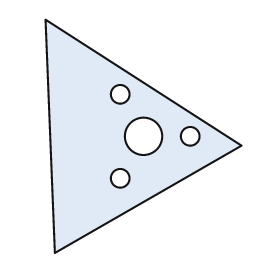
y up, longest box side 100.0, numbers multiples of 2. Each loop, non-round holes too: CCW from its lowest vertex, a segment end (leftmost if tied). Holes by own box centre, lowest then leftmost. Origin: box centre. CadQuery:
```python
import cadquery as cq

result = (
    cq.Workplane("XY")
    .moveTo(-38.0, -50.0)
    .lineTo(42.0, -4.0)
    .lineTo(-42.0, 50.0)
    .close()
    .moveTo(-10.0, -18.0)
    .circle(4.0)
    .moveTo(0.0, 0.0)
    .circle(8.0)
    .moveTo(20.0, 0.0)
    .circle(4.0)
    .moveTo(-10.0, 18.0)
    .circle(4.0)
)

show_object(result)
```